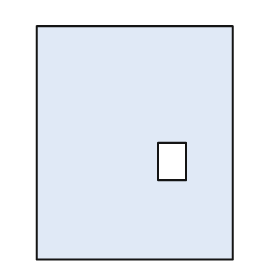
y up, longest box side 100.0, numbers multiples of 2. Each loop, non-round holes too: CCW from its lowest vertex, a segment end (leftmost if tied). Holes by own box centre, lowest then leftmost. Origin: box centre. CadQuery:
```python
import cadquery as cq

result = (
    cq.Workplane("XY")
    .moveTo(-42.0, -50.0)
    .lineTo(42.0, -50.0)
    .lineTo(42.0, 50.0)
    .lineTo(-42.0, 50.0)
    .close()
    .moveTo(10.0, -16.0)
    .lineTo(22.0, -16.0)
    .lineTo(22.0, 0.0)
    .lineTo(10.0, 0.0)
    .close()
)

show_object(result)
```